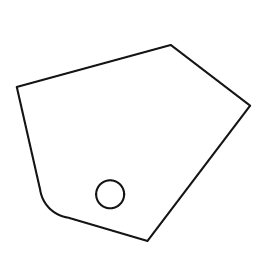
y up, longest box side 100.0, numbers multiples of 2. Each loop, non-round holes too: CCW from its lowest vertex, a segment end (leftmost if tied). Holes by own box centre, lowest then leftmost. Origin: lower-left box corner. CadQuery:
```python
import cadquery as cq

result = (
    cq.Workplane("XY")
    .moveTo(56.0, 0.0)
    .lineTo(100.0, 58.0)
    .lineTo(66.0, 84.0)
    .lineTo(0.0, 66.0)
    .lineTo(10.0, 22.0)
    .threePointArc((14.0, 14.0), (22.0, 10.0))
    .close()
    .moveTo(40.0, 20.0)
    .circle(6.0)
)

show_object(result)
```